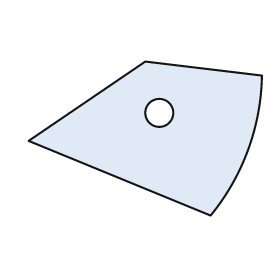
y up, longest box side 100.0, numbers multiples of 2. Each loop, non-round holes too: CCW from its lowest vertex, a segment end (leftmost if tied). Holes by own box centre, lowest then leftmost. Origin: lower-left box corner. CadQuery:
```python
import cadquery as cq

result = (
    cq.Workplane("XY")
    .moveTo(78.0, 0.0)
    .threePointArc((94.0, 28.0), (100.0, 60.0))
    .lineTo(50.0, 66.0)
    .lineTo(0.0, 32.0)
    .close()
    .moveTo(56.0, 44.0)
    .circle(6.0)
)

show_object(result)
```